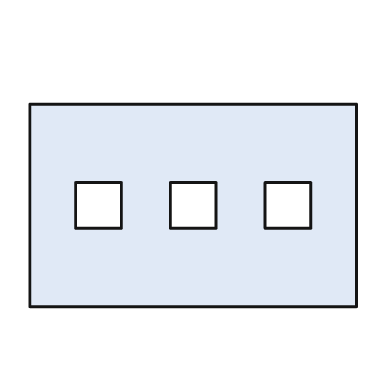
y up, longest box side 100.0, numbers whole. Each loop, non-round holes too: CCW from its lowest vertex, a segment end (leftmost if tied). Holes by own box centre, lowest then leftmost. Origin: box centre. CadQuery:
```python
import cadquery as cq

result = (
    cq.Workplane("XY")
    .moveTo(-50.0, -31.0)
    .lineTo(50.0, -31.0)
    .lineTo(50.0, 31.0)
    .lineTo(-50.0, 31.0)
    .close()
    .moveTo(-36.0, -7.0)
    .lineTo(-22.0, -7.0)
    .lineTo(-22.0, 7.0)
    .lineTo(-36.0, 7.0)
    .close()
    .moveTo(-7.0, -7.0)
    .lineTo(7.0, -7.0)
    .lineTo(7.0, 7.0)
    .lineTo(-7.0, 7.0)
    .close()
    .moveTo(22.0, -7.0)
    .lineTo(36.0, -7.0)
    .lineTo(36.0, 7.0)
    .lineTo(22.0, 7.0)
    .close()
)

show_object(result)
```